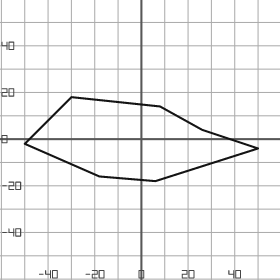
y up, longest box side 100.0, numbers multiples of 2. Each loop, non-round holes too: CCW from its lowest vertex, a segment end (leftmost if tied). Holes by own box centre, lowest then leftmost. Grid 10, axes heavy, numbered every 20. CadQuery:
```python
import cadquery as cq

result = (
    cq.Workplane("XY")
    .moveTo(6.0, -18.0)
    .lineTo(50.0, -4.0)
    .lineTo(26.0, 4.0)
    .lineTo(8.0, 14.0)
    .lineTo(-30.0, 18.0)
    .lineTo(-50.0, -2.0)
    .lineTo(-18.0, -16.0)
    .close()
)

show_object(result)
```